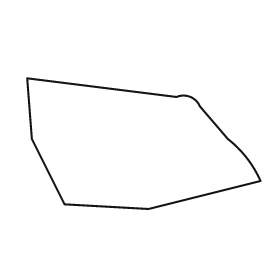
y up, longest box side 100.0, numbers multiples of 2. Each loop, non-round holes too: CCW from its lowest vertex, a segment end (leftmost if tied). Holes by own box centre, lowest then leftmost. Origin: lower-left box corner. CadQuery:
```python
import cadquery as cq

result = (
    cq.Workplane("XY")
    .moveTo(52.0, 0.0)
    .lineTo(100.0, 12.0)
    .threePointArc((94.0, 22.0), (86.0, 30.0))
    .lineTo(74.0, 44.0)
    .threePointArc((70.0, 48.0), (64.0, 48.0))
    .lineTo(0.0, 56.0)
    .lineTo(2.0, 30.0)
    .lineTo(16.0, 2.0)
    .close()
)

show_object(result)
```